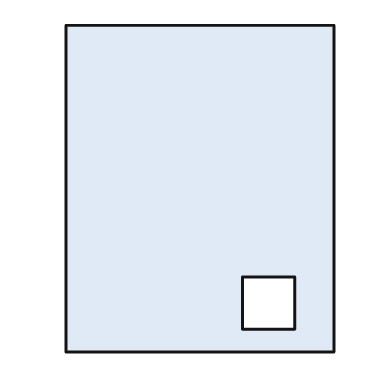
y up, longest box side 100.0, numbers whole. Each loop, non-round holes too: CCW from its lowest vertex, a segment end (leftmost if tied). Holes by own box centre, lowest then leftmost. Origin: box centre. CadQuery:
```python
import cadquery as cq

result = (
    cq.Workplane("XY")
    .moveTo(-41.0, -50.0)
    .lineTo(41.0, -50.0)
    .lineTo(41.0, 50.0)
    .lineTo(-41.0, 50.0)
    .close()
    .moveTo(13.0, -43.0)
    .lineTo(29.0, -43.0)
    .lineTo(29.0, -27.0)
    .lineTo(13.0, -27.0)
    .close()
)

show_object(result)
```